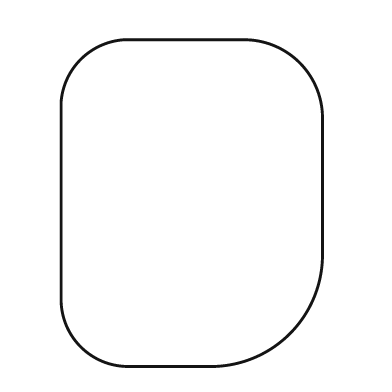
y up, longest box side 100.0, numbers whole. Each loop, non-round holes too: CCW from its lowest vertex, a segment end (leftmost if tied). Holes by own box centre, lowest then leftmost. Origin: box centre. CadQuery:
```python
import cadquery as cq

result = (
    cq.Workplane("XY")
    .moveTo(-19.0, -50.0)
    .lineTo(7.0, -50.0)
    .threePointArc((30.0, -40.0), (40.0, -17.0))
    .lineTo(40.0, 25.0)
    .threePointArc((33.0, 43.0), (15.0, 50.0))
    .lineTo(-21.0, 50.0)
    .threePointArc((-34.0, 44.0), (-40.0, 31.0))
    .lineTo(-40.0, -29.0)
    .threePointArc((-34.0, -44.0), (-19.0, -50.0))
    .close()
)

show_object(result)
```